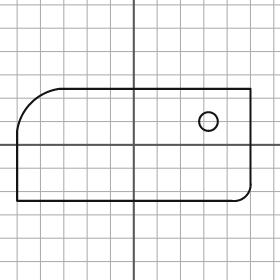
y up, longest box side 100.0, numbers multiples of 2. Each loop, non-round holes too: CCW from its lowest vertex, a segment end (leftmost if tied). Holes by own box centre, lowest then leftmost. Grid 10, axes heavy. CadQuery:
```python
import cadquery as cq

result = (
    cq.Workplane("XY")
    .moveTo(-50.0, -24.0)
    .lineTo(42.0, -24.0)
    .threePointArc((48.0, -22.0), (50.0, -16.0))
    .lineTo(50.0, 24.0)
    .lineTo(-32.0, 24.0)
    .threePointArc((-44.0, 18.0), (-50.0, 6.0))
    .close()
    .moveTo(32.0, 10.0)
    .circle(4.0)
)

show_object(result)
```